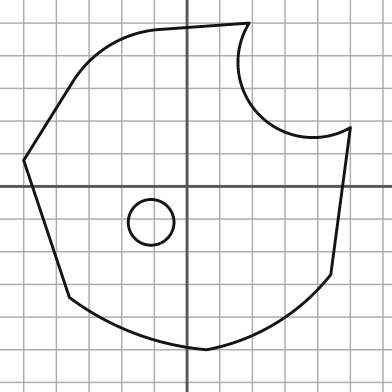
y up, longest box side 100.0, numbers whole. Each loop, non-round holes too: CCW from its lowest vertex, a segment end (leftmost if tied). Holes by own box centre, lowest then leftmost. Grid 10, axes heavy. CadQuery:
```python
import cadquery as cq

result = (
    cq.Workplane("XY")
    .moveTo(6.0, -50.0)
    .threePointArc((27.0, -42.0), (44.0, -27.0))
    .lineTo(50.0, 18.0)
    .threePointArc((22.0, 22.0), (19.0, 50.0))
    .lineTo(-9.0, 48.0)
    .threePointArc((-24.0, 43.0), (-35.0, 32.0))
    .lineTo(-50.0, 8.0)
    .lineTo(-36.0, -34.0)
    .threePointArc((-16.0, -45.0), (6.0, -50.0))
    .close()
    .moveTo(-11.0, -11.0)
    .circle(7.0)
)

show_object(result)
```